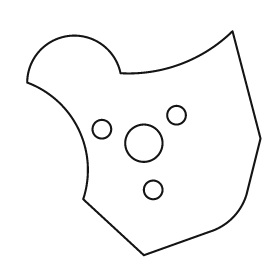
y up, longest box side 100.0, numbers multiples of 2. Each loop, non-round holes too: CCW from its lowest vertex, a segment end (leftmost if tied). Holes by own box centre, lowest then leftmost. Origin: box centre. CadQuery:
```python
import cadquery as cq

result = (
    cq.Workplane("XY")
    .moveTo(0.0, -48.0)
    .lineTo(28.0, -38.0)
    .threePointArc((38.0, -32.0), (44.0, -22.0))
    .lineTo(50.0, 2.0)
    .lineTo(38.0, 48.0)
    .threePointArc((16.0, 34.0), (-10.0, 30.0))
    .threePointArc((-32.0, 46.0), (-50.0, 26.0))
    .threePointArc((-28.0, 6.0), (-26.0, -24.0))
    .close()
    .moveTo(4.0, -20.0)
    .circle(4.0)
    .moveTo(0.0, 0.0)
    .circle(8.0)
    .moveTo(-18.0, 6.0)
    .circle(4.0)
    .moveTo(14.0, 12.0)
    .circle(4.0)
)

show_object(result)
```